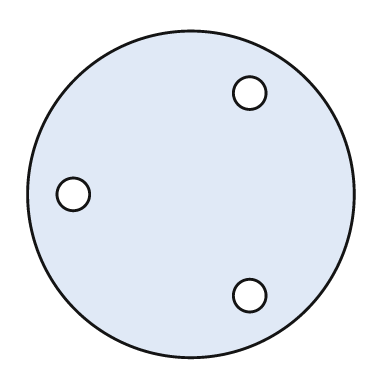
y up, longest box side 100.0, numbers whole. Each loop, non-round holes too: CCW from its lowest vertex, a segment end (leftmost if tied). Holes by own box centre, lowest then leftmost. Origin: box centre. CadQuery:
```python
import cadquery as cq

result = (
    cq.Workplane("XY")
    .moveTo(0.0, 0.0)
    .circle(50.0)
    .moveTo(18.0, -31.0)
    .circle(5.0)
    .moveTo(-36.0, 0.0)
    .circle(5.0)
    .moveTo(18.0, 31.0)
    .circle(5.0)
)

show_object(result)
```